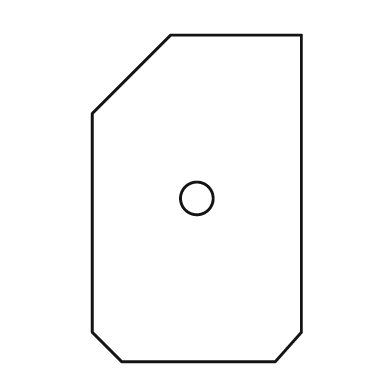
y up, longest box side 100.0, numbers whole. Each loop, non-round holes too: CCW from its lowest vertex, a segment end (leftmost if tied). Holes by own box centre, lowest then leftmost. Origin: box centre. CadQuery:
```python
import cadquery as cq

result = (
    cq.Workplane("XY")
    .moveTo(-23.0, -50.0)
    .lineTo(24.0, -50.0)
    .lineTo(32.0, -41.0)
    .lineTo(32.0, 50.0)
    .lineTo(-8.0, 50.0)
    .lineTo(-32.0, 26.0)
    .lineTo(-32.0, -41.0)
    .close()
    .moveTo(0.0, 0.0)
    .circle(5.0)
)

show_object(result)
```